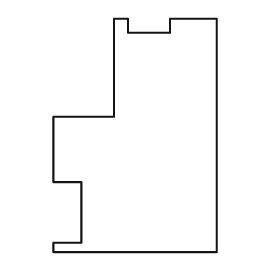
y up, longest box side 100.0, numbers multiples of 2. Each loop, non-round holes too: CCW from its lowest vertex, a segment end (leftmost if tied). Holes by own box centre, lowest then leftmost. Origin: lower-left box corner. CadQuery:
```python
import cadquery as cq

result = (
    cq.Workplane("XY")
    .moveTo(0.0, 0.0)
    .lineTo(70.0, 0.0)
    .lineTo(70.0, 100.0)
    .lineTo(50.0, 100.0)
    .lineTo(50.0, 94.0)
    .lineTo(32.0, 94.0)
    .lineTo(32.0, 100.0)
    .lineTo(26.0, 100.0)
    .lineTo(26.0, 58.0)
    .lineTo(0.0, 58.0)
    .lineTo(0.0, 30.0)
    .lineTo(12.0, 30.0)
    .lineTo(12.0, 4.0)
    .lineTo(0.0, 4.0)
    .close()
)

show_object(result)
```